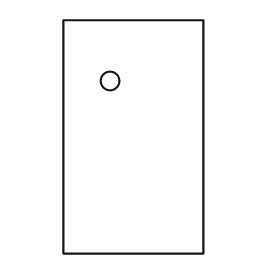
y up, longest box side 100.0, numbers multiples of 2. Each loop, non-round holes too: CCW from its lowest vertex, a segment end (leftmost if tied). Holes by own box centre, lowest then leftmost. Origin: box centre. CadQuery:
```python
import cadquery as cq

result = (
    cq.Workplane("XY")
    .moveTo(-30.0, -50.0)
    .lineTo(30.0, -50.0)
    .lineTo(30.0, 50.0)
    .lineTo(-30.0, 50.0)
    .close()
    .moveTo(-10.0, 24.0)
    .circle(4.0)
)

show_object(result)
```